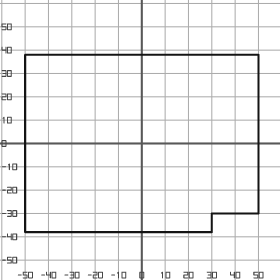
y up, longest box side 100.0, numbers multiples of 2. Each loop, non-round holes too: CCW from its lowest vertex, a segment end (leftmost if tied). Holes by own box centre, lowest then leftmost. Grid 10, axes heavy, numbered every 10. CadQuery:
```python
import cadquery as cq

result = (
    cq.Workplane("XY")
    .moveTo(-50.0, -38.0)
    .lineTo(30.0, -38.0)
    .lineTo(30.0, -30.0)
    .lineTo(50.0, -30.0)
    .lineTo(50.0, 38.0)
    .lineTo(-50.0, 38.0)
    .close()
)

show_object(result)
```